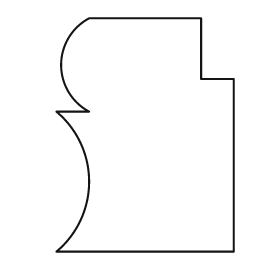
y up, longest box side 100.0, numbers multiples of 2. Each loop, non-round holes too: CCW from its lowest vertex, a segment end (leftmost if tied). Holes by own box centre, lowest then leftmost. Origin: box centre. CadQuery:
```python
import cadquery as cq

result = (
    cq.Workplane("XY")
    .moveTo(-38.0, -50.0)
    .lineTo(38.0, -50.0)
    .lineTo(38.0, 24.0)
    .lineTo(24.0, 24.0)
    .lineTo(24.0, 50.0)
    .lineTo(-24.0, 50.0)
    .threePointArc((-36.0, 30.0), (-24.0, 10.0))
    .lineTo(-38.0, 10.0)
    .threePointArc((-24.0, -20.0), (-38.0, -50.0))
    .close()
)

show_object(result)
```